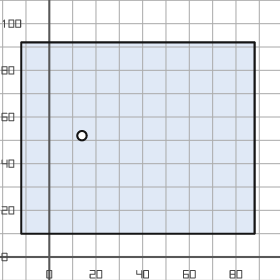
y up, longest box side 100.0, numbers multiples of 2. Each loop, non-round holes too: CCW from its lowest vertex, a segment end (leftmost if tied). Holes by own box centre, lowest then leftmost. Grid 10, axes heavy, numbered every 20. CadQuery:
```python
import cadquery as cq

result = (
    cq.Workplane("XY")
    .moveTo(-12.0, 10.0)
    .lineTo(88.0, 10.0)
    .lineTo(88.0, 92.0)
    .lineTo(-12.0, 92.0)
    .close()
    .moveTo(14.0, 52.0)
    .circle(2.0)
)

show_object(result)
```